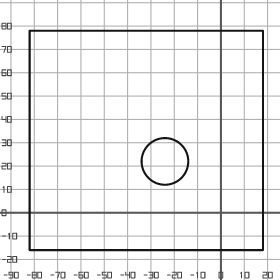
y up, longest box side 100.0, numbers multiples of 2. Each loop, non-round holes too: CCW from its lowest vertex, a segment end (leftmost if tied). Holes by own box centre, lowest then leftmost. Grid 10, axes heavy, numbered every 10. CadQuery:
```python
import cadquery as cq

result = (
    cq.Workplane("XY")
    .moveTo(-82.0, -16.0)
    .lineTo(18.0, -16.0)
    .lineTo(18.0, 78.0)
    .lineTo(-82.0, 78.0)
    .close()
    .moveTo(-24.0, 22.0)
    .circle(10.0)
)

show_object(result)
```